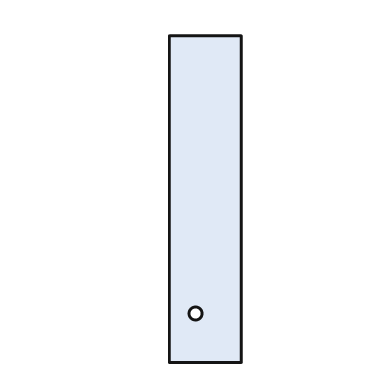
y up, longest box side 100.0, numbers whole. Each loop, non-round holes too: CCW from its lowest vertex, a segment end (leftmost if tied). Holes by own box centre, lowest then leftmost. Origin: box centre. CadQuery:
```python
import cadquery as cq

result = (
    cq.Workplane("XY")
    .moveTo(-11.0, -50.0)
    .lineTo(11.0, -50.0)
    .lineTo(11.0, 50.0)
    .lineTo(-11.0, 50.0)
    .close()
    .moveTo(-3.0, -35.0)
    .circle(2.0)
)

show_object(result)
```